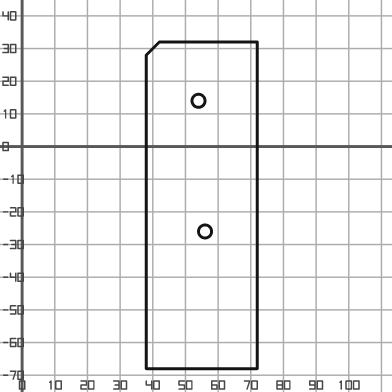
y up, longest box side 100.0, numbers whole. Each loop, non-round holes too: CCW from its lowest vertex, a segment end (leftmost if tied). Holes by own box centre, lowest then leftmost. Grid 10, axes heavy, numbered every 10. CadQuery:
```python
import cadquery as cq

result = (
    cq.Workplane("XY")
    .moveTo(38.0, -68.0)
    .lineTo(72.0, -68.0)
    .lineTo(72.0, 32.0)
    .lineTo(42.0, 32.0)
    .lineTo(38.0, 28.0)
    .close()
    .moveTo(56.0, -26.0)
    .circle(2.0)
    .moveTo(54.0, 14.0)
    .circle(2.0)
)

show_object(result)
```